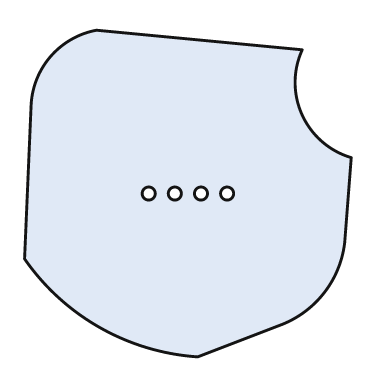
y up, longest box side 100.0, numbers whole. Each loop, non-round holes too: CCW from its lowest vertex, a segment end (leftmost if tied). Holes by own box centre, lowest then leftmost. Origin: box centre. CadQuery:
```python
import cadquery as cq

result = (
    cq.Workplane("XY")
    .moveTo(3.0, -50.0)
    .lineTo(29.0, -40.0)
    .threePointArc((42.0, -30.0), (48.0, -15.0))
    .lineTo(50.0, 11.0)
    .threePointArc((35.0, 24.0), (35.0, 44.0))
    .lineTo(-28.0, 50.0)
    .threePointArc((-42.0, 42.0), (-48.0, 27.0))
    .lineTo(-50.0, -20.0)
    .threePointArc((-27.0, -41.0), (3.0, -50.0))
    .close()
    .moveTo(-12.0, 0.0)
    .circle(2.0)
    .moveTo(-4.0, 0.0)
    .circle(2.0)
    .moveTo(4.0, 0.0)
    .circle(2.0)
    .moveTo(12.0, 0.0)
    .circle(2.0)
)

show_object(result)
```